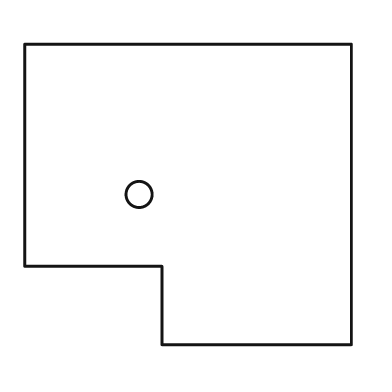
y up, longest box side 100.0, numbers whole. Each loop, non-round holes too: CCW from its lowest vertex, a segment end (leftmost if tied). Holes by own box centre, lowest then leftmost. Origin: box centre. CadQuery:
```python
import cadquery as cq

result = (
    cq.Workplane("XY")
    .moveTo(-8.0, -46.0)
    .lineTo(50.0, -46.0)
    .lineTo(50.0, 46.0)
    .lineTo(-50.0, 46.0)
    .lineTo(-50.0, -22.0)
    .lineTo(-8.0, -22.0)
    .close()
    .moveTo(-15.0, 0.0)
    .circle(4.0)
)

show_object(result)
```